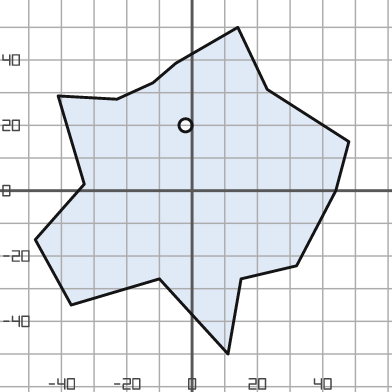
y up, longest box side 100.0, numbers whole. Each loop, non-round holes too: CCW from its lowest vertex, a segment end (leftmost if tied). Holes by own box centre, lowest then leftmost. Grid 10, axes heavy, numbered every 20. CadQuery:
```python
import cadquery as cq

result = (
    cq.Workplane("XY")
    .moveTo(11.0, -50.0)
    .lineTo(15.0, -27.0)
    .lineTo(32.0, -23.0)
    .lineTo(44.0, 0.0)
    .lineTo(48.0, 15.0)
    .lineTo(23.0, 31.0)
    .lineTo(14.0, 50.0)
    .lineTo(-5.0, 39.0)
    .lineTo(-12.0, 33.0)
    .lineTo(-23.0, 28.0)
    .lineTo(-41.0, 29.0)
    .lineTo(-33.0, 2.0)
    .lineTo(-48.0, -15.0)
    .lineTo(-37.0, -35.0)
    .lineTo(-10.0, -27.0)
    .close()
    .moveTo(-2.0, 20.0)
    .circle(2.0)
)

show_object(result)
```